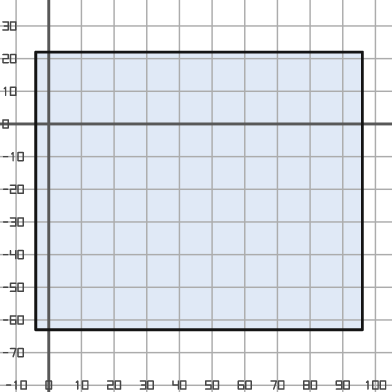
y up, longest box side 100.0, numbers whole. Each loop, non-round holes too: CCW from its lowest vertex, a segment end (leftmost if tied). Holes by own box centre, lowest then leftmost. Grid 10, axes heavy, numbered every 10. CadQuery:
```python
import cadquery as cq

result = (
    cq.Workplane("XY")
    .moveTo(-4.0, -63.0)
    .lineTo(96.0, -63.0)
    .lineTo(96.0, 22.0)
    .lineTo(-4.0, 22.0)
    .close()
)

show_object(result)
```